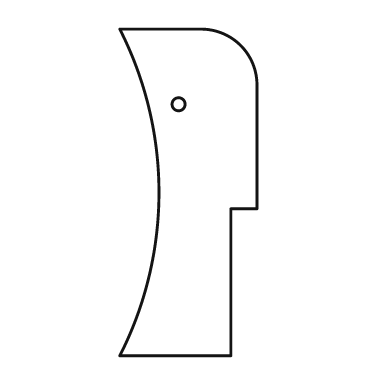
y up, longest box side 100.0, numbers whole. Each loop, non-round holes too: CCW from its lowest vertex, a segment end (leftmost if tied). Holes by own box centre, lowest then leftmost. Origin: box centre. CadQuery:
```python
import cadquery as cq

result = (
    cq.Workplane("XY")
    .moveTo(-21.0, -50.0)
    .lineTo(13.0, -50.0)
    .lineTo(13.0, -5.0)
    .lineTo(21.0, -5.0)
    .lineTo(21.0, 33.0)
    .threePointArc((16.0, 45.0), (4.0, 50.0))
    .lineTo(-21.0, 50.0)
    .threePointArc((-9.0, 0.0), (-21.0, -50.0))
    .close()
    .moveTo(-3.0, 27.0)
    .circle(2.0)
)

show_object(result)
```